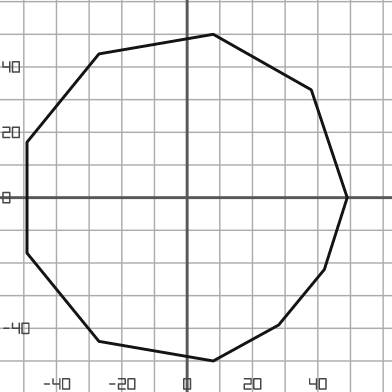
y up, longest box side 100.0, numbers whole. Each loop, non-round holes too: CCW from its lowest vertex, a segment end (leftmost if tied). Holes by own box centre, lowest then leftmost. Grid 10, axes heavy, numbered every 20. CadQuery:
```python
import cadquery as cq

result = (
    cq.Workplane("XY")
    .moveTo(8.0, -50.0)
    .lineTo(28.0, -39.0)
    .lineTo(42.0, -22.0)
    .lineTo(49.0, 0.0)
    .lineTo(38.0, 33.0)
    .lineTo(8.0, 50.0)
    .lineTo(-27.0, 44.0)
    .lineTo(-49.0, 17.0)
    .lineTo(-49.0, -17.0)
    .lineTo(-27.0, -44.0)
    .close()
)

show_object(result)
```